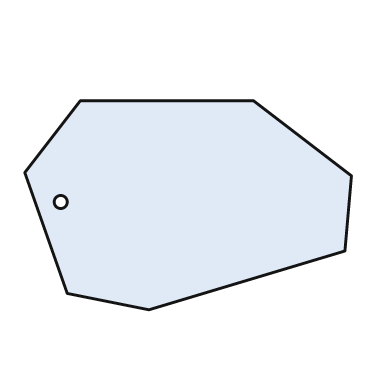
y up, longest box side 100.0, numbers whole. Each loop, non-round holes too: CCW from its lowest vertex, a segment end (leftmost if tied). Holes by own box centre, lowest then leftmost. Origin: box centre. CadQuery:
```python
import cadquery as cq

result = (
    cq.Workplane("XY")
    .moveTo(-12.0, -32.0)
    .lineTo(48.0, -14.0)
    .lineTo(50.0, 9.0)
    .lineTo(20.0, 32.0)
    .lineTo(-33.0, 32.0)
    .lineTo(-50.0, 10.0)
    .lineTo(-37.0, -27.0)
    .close()
    .moveTo(-39.0, 1.0)
    .circle(2.0)
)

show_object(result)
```